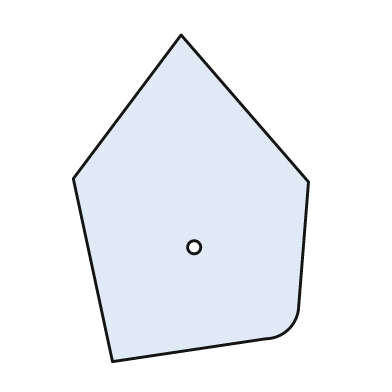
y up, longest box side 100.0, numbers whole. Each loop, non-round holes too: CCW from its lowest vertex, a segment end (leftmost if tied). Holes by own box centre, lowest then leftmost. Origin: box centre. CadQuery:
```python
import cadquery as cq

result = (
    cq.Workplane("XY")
    .moveTo(-24.0, -50.0)
    .lineTo(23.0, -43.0)
    .threePointArc((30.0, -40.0), (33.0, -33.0))
    .lineTo(36.0, 5.0)
    .lineTo(-3.0, 50.0)
    .lineTo(-36.0, 6.0)
    .close()
    .moveTo(1.0, -15.0)
    .circle(2.0)
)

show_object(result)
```